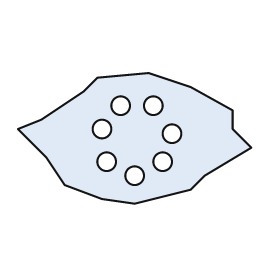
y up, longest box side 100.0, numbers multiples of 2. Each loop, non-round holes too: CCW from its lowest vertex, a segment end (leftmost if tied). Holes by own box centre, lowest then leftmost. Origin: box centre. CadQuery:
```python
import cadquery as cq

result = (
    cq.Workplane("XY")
    .moveTo(0.0, -28.0)
    .lineTo(24.0, -22.0)
    .lineTo(30.0, -16.0)
    .lineTo(50.0, -4.0)
    .lineTo(42.0, 4.0)
    .lineTo(42.0, 12.0)
    .lineTo(24.0, 22.0)
    .lineTo(6.0, 28.0)
    .lineTo(-16.0, 26.0)
    .lineTo(-22.0, 20.0)
    .lineTo(-40.0, 8.0)
    .lineTo(-50.0, 4.0)
    .lineTo(-38.0, -8.0)
    .lineTo(-30.0, -20.0)
    .lineTo(-14.0, -26.0)
    .close()
    .moveTo(0.0, -16.0)
    .circle(4.0)
    .moveTo(-12.0, -10.0)
    .circle(4.0)
    .moveTo(12.0, -10.0)
    .circle(4.0)
    .moveTo(16.0, 2.0)
    .circle(4.0)
    .moveTo(-14.0, 4.0)
    .circle(4.0)
    .moveTo(-6.0, 14.0)
    .circle(4.0)
    .moveTo(8.0, 14.0)
    .circle(4.0)
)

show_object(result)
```